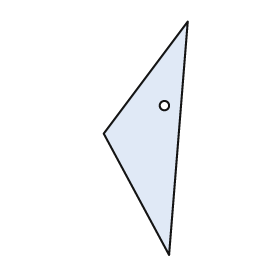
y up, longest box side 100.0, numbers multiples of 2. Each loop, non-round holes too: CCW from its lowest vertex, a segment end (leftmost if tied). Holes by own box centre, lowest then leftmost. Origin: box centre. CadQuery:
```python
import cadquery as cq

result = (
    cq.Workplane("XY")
    .moveTo(10.0, -50.0)
    .lineTo(18.0, 50.0)
    .lineTo(-18.0, 2.0)
    .close()
    .moveTo(8.0, 14.0)
    .circle(2.0)
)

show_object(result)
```